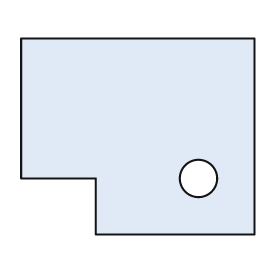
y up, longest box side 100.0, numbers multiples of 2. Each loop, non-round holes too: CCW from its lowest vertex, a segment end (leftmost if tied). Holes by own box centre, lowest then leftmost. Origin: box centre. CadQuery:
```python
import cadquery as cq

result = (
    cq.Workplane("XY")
    .moveTo(-18.0, -42.0)
    .lineTo(50.0, -42.0)
    .lineTo(50.0, 42.0)
    .lineTo(-50.0, 42.0)
    .lineTo(-50.0, -18.0)
    .lineTo(-18.0, -18.0)
    .close()
    .moveTo(26.0, -18.0)
    .circle(8.0)
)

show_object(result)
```